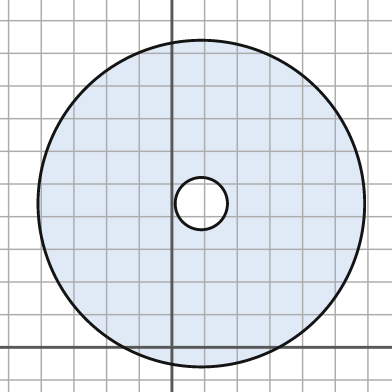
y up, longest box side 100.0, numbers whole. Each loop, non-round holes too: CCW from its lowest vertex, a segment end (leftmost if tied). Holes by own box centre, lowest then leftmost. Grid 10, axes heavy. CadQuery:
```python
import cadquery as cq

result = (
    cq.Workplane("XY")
    .moveTo(9.0, 44.0)
    .circle(50.0)
    .moveTo(9.0, 44.0)
    .circle(8.0)
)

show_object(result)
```